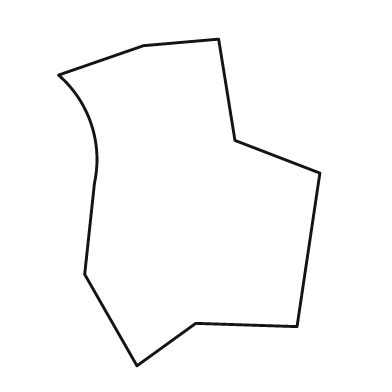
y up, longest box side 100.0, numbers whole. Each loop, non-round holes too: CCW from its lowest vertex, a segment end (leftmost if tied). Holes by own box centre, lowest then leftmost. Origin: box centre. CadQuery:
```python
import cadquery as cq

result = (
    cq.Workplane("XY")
    .moveTo(-16.0, -50.0)
    .lineTo(2.0, -37.0)
    .lineTo(33.0, -38.0)
    .lineTo(40.0, 9.0)
    .lineTo(14.0, 19.0)
    .lineTo(9.0, 50.0)
    .lineTo(-14.0, 48.0)
    .lineTo(-40.0, 39.0)
    .threePointArc((-30.0, 24.0), (-29.0, 6.0))
    .lineTo(-32.0, -22.0)
    .close()
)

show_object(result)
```